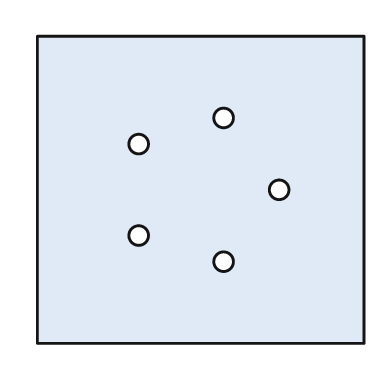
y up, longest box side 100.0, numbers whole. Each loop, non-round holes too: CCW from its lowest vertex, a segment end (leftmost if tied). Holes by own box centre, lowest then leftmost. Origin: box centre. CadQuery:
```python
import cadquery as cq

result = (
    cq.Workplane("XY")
    .moveTo(-50.0, -47.0)
    .lineTo(50.0, -47.0)
    .lineTo(50.0, 47.0)
    .lineTo(-50.0, 47.0)
    .close()
    .moveTo(7.0, -22.0)
    .circle(3.0)
    .moveTo(-19.0, -14.0)
    .circle(3.0)
    .moveTo(24.0, 0.0)
    .circle(3.0)
    .moveTo(-19.0, 14.0)
    .circle(3.0)
    .moveTo(7.0, 22.0)
    .circle(3.0)
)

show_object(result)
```